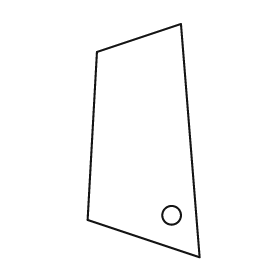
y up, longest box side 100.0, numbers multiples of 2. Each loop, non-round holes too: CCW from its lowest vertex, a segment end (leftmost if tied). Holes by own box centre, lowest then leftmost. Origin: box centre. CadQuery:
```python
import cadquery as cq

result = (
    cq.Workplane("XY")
    .moveTo(24.0, -50.0)
    .lineTo(16.0, 50.0)
    .lineTo(-20.0, 38.0)
    .lineTo(-24.0, -34.0)
    .close()
    .moveTo(12.0, -32.0)
    .circle(4.0)
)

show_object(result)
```